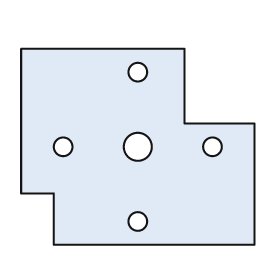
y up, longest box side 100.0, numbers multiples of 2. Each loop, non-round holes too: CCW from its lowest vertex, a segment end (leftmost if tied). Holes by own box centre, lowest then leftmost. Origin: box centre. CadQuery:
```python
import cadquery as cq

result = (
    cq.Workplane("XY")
    .moveTo(-36.0, -42.0)
    .lineTo(50.0, -42.0)
    .lineTo(50.0, 10.0)
    .lineTo(20.0, 10.0)
    .lineTo(20.0, 42.0)
    .lineTo(-50.0, 42.0)
    .lineTo(-50.0, -20.0)
    .lineTo(-36.0, -20.0)
    .close()
    .moveTo(0.0, -32.0)
    .circle(4.0)
    .moveTo(-32.0, 0.0)
    .circle(4.0)
    .moveTo(0.0, 0.0)
    .circle(6.0)
    .moveTo(32.0, 0.0)
    .circle(4.0)
    .moveTo(0.0, 32.0)
    .circle(4.0)
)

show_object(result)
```